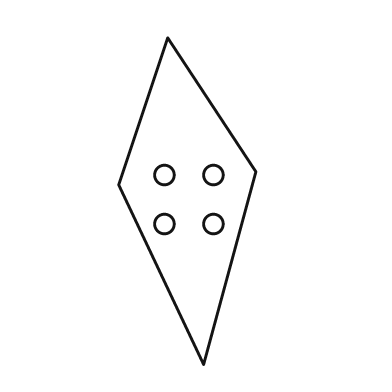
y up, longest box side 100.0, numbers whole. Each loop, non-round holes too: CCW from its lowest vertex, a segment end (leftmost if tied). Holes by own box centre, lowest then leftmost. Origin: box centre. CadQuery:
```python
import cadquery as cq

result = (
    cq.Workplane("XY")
    .moveTo(5.0, -50.0)
    .lineTo(21.0, 9.0)
    .lineTo(-6.0, 50.0)
    .lineTo(-21.0, 5.0)
    .close()
    .moveTo(-7.0, -7.0)
    .circle(3.0)
    .moveTo(8.0, -7.0)
    .circle(3.0)
    .moveTo(-7.0, 8.0)
    .circle(3.0)
    .moveTo(8.0, 8.0)
    .circle(3.0)
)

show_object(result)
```